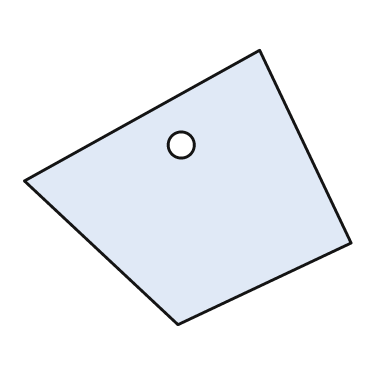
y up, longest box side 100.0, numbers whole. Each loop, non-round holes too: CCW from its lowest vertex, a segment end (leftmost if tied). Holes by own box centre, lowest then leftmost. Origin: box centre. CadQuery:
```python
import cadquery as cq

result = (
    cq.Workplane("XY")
    .moveTo(-3.0, -42.0)
    .lineTo(50.0, -17.0)
    .lineTo(22.0, 42.0)
    .lineTo(-50.0, 2.0)
    .close()
    .moveTo(-2.0, 13.0)
    .circle(4.0)
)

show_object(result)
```